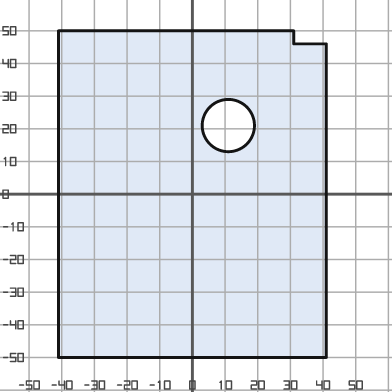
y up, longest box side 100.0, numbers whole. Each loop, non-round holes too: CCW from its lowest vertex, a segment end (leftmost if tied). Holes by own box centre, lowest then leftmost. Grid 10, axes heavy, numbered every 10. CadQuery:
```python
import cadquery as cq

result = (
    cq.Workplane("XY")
    .moveTo(-41.0, -50.0)
    .lineTo(41.0, -50.0)
    .lineTo(41.0, 46.0)
    .lineTo(31.0, 46.0)
    .lineTo(31.0, 50.0)
    .lineTo(-41.0, 50.0)
    .close()
    .moveTo(11.0, 21.0)
    .circle(8.0)
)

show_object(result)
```